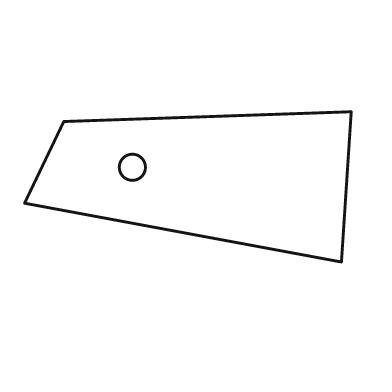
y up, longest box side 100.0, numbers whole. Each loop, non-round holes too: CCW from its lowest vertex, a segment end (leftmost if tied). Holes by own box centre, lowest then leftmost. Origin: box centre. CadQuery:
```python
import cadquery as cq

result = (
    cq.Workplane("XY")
    .moveTo(47.0, -23.0)
    .lineTo(50.0, 23.0)
    .lineTo(-38.0, 20.0)
    .lineTo(-50.0, -5.0)
    .close()
    .moveTo(-17.0, 6.0)
    .circle(4.0)
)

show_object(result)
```